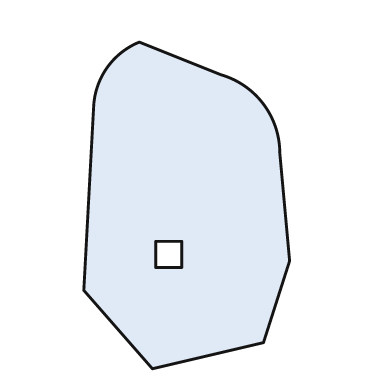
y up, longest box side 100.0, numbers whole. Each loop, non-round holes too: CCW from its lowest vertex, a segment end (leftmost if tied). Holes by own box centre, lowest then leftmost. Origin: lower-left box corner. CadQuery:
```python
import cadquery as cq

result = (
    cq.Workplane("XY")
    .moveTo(21.0, 0.0)
    .lineTo(55.0, 8.0)
    .lineTo(63.0, 33.0)
    .lineTo(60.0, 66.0)
    .threePointArc((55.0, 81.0), (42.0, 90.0))
    .lineTo(17.0, 100.0)
    .threePointArc((7.0, 92.0), (3.0, 80.0))
    .lineTo(0.0, 24.0)
    .close()
    .moveTo(22.0, 31.0)
    .lineTo(30.0, 31.0)
    .lineTo(30.0, 39.0)
    .lineTo(22.0, 39.0)
    .close()
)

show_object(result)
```